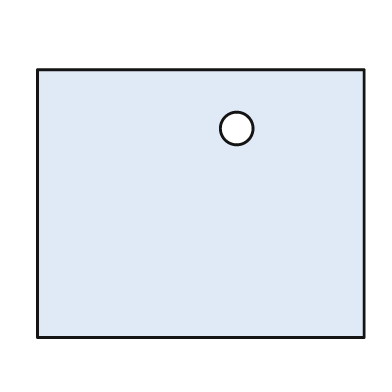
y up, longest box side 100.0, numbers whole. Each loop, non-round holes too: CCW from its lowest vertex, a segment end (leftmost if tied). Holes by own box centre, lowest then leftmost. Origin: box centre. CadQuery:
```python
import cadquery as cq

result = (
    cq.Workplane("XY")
    .moveTo(-50.0, -41.0)
    .lineTo(50.0, -41.0)
    .lineTo(50.0, 41.0)
    .lineTo(-50.0, 41.0)
    .close()
    .moveTo(11.0, 23.0)
    .circle(5.0)
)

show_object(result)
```